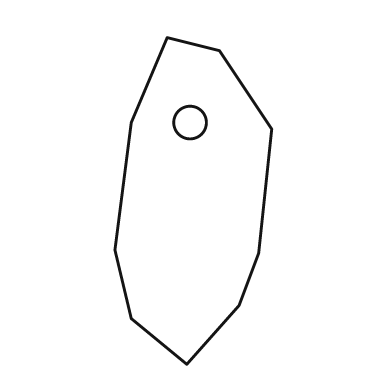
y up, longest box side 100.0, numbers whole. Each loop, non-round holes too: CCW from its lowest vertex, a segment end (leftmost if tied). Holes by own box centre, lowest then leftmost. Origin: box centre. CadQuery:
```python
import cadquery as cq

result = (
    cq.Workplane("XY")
    .moveTo(-2.0, -50.0)
    .lineTo(14.0, -32.0)
    .lineTo(20.0, -16.0)
    .lineTo(24.0, 22.0)
    .lineTo(8.0, 46.0)
    .lineTo(-8.0, 50.0)
    .lineTo(-19.0, 24.0)
    .lineTo(-24.0, -15.0)
    .lineTo(-19.0, -36.0)
    .close()
    .moveTo(-1.0, 24.0)
    .circle(5.0)
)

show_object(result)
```